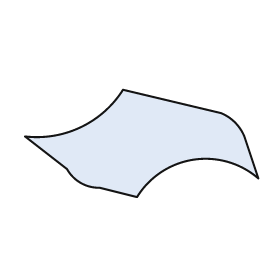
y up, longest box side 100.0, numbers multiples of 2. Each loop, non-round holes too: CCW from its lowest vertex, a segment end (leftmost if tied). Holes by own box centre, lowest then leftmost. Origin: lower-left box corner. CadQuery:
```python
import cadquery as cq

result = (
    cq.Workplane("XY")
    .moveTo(48.0, 0.0)
    .threePointArc((72.0, 16.0), (100.0, 8.0))
    .lineTo(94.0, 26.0)
    .threePointArc((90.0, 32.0), (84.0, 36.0))
    .lineTo(42.0, 46.0)
    .threePointArc((24.0, 30.0), (0.0, 26.0))
    .lineTo(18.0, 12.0)
    .threePointArc((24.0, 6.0), (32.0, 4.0))
    .close()
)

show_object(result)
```